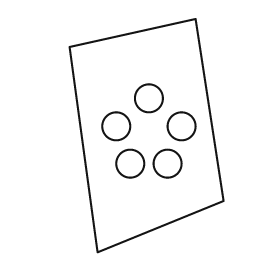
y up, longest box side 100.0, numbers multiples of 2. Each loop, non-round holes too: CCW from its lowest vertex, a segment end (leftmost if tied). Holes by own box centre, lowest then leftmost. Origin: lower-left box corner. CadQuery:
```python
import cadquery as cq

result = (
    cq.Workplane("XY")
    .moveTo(12.0, 0.0)
    .lineTo(66.0, 22.0)
    .lineTo(54.0, 100.0)
    .lineTo(0.0, 88.0)
    .close()
    .moveTo(26.0, 38.0)
    .circle(6.0)
    .moveTo(42.0, 38.0)
    .circle(6.0)
    .moveTo(20.0, 54.0)
    .circle(6.0)
    .moveTo(48.0, 54.0)
    .circle(6.0)
    .moveTo(34.0, 66.0)
    .circle(6.0)
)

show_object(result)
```